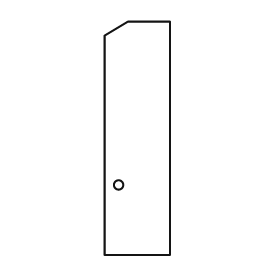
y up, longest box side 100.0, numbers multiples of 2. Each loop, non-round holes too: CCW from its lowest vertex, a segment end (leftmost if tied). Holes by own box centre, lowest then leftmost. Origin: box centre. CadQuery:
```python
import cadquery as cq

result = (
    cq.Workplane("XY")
    .moveTo(-14.0, -50.0)
    .lineTo(14.0, -50.0)
    .lineTo(14.0, 50.0)
    .lineTo(-4.0, 50.0)
    .lineTo(-14.0, 44.0)
    .close()
    .moveTo(-8.0, -20.0)
    .circle(2.0)
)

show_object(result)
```